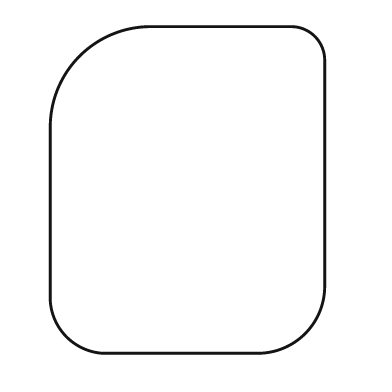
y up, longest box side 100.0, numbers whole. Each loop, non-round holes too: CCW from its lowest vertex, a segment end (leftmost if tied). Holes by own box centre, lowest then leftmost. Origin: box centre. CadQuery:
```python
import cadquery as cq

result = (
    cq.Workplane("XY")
    .moveTo(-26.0, -50.0)
    .lineTo(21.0, -50.0)
    .threePointArc((36.0, -44.0), (42.0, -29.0))
    .lineTo(42.0, 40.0)
    .threePointArc((39.0, 47.0), (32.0, 50.0))
    .lineTo(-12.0, 50.0)
    .threePointArc((-33.0, 41.0), (-42.0, 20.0))
    .lineTo(-42.0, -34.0)
    .threePointArc((-37.0, -45.0), (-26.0, -50.0))
    .close()
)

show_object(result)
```